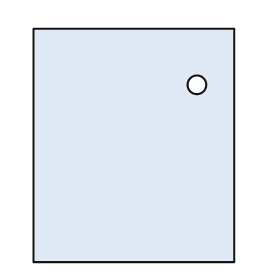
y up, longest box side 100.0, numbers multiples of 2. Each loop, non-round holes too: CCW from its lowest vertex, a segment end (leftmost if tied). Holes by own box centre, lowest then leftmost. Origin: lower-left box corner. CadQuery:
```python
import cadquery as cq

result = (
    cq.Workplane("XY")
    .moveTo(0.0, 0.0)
    .lineTo(86.0, 0.0)
    .lineTo(86.0, 100.0)
    .lineTo(0.0, 100.0)
    .close()
    .moveTo(70.0, 76.0)
    .circle(4.0)
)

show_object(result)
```